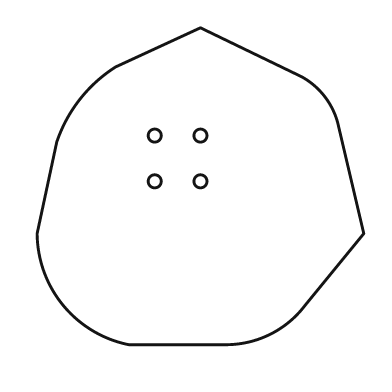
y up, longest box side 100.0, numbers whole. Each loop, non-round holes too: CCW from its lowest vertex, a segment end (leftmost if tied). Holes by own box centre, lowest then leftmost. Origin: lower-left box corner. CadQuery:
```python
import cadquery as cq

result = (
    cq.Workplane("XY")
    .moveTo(28.0, 0.0)
    .lineTo(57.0, 0.0)
    .threePointArc((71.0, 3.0), (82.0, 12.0))
    .lineTo(100.0, 34.0)
    .lineTo(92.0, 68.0)
    .threePointArc((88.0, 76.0), (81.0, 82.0))
    .lineTo(50.0, 97.0)
    .lineTo(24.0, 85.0)
    .threePointArc((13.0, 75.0), (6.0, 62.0))
    .lineTo(0.0, 34.0)
    .threePointArc((8.0, 12.0), (28.0, 0.0))
    .close()
    .moveTo(36.0, 50.0)
    .circle(2.0)
    .moveTo(50.0, 50.0)
    .circle(2.0)
    .moveTo(36.0, 64.0)
    .circle(2.0)
    .moveTo(50.0, 64.0)
    .circle(2.0)
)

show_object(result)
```